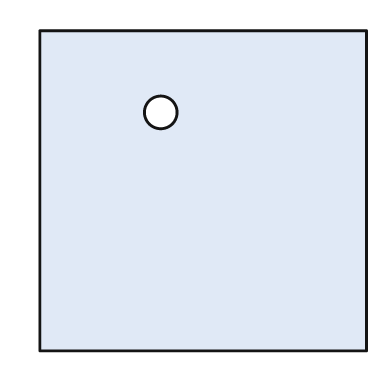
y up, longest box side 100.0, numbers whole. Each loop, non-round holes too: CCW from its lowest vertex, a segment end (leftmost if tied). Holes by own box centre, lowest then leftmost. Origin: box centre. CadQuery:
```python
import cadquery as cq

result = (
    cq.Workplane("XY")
    .moveTo(-50.0, -49.0)
    .lineTo(50.0, -49.0)
    .lineTo(50.0, 49.0)
    .lineTo(-50.0, 49.0)
    .close()
    .moveTo(-13.0, 24.0)
    .circle(5.0)
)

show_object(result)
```